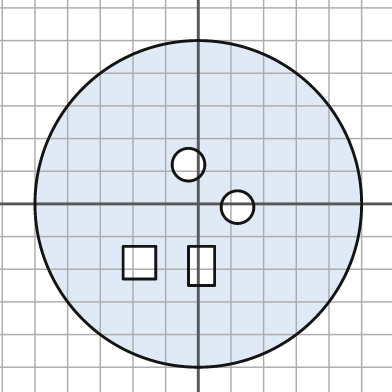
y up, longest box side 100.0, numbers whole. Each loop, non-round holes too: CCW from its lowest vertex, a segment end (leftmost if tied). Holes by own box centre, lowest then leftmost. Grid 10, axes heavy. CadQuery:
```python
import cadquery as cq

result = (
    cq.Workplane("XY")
    .moveTo(0.0, 0.0)
    .circle(50.0)
    .moveTo(-3.0, -25.0)
    .lineTo(5.0, -25.0)
    .lineTo(5.0, -13.0)
    .lineTo(-3.0, -13.0)
    .close()
    .moveTo(-23.0, -23.0)
    .lineTo(-13.0, -23.0)
    .lineTo(-13.0, -13.0)
    .lineTo(-23.0, -13.0)
    .close()
    .moveTo(12.0, -1.0)
    .circle(5.0)
    .moveTo(-3.0, 12.0)
    .circle(5.0)
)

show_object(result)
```